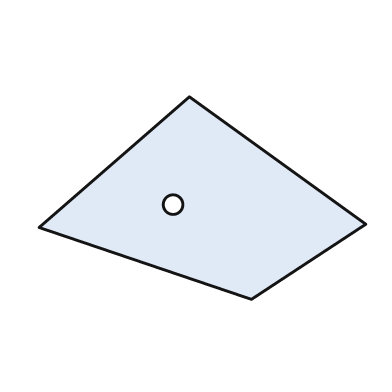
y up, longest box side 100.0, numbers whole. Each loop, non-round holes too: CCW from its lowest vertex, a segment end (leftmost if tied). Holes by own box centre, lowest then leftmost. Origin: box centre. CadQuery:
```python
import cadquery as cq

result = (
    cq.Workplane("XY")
    .moveTo(15.0, -31.0)
    .lineTo(50.0, -8.0)
    .lineTo(-4.0, 31.0)
    .lineTo(-50.0, -9.0)
    .close()
    .moveTo(-9.0, -2.0)
    .circle(3.0)
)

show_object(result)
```